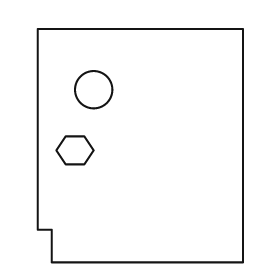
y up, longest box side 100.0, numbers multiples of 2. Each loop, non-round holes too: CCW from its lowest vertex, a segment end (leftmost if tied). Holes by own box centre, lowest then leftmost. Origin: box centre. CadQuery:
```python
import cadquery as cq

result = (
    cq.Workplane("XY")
    .moveTo(-38.0, -50.0)
    .lineTo(44.0, -50.0)
    .lineTo(44.0, 50.0)
    .lineTo(-44.0, 50.0)
    .lineTo(-44.0, -36.0)
    .lineTo(-38.0, -36.0)
    .close()
    .moveTo(-32.0, -8.0)
    .lineTo(-24.0, -8.0)
    .lineTo(-20.0, -2.0)
    .lineTo(-24.0, 4.0)
    .lineTo(-32.0, 4.0)
    .lineTo(-36.0, -2.0)
    .close()
    .moveTo(-20.0, 24.0)
    .circle(8.0)
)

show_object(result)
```